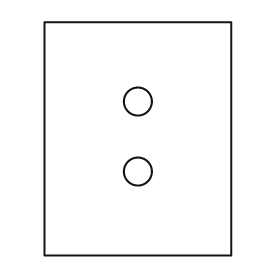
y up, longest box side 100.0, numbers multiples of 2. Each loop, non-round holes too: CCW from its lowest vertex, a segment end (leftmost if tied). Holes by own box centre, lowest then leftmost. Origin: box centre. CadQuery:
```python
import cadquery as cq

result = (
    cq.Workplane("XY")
    .moveTo(-40.0, -50.0)
    .lineTo(40.0, -50.0)
    .lineTo(40.0, 50.0)
    .lineTo(-40.0, 50.0)
    .close()
    .moveTo(0.0, -14.0)
    .circle(6.0)
    .moveTo(0.0, 16.0)
    .circle(6.0)
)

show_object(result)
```